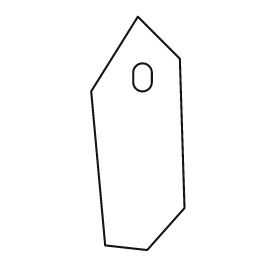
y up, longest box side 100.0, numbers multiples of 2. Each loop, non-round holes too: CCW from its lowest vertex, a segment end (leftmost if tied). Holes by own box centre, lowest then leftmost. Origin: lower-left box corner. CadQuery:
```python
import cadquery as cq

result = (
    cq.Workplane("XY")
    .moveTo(24.0, 0.0)
    .lineTo(40.0, 18.0)
    .lineTo(38.0, 82.0)
    .lineTo(20.0, 100.0)
    .lineTo(0.0, 68.0)
    .lineTo(6.0, 2.0)
    .close()
    .moveTo(18.0, 72.0)
    .threePointArc((22.0, 68.0), (26.0, 72.0))
    .lineTo(26.0, 76.0)
    .threePointArc((22.0, 80.0), (18.0, 76.0))
    .close()
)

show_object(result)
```